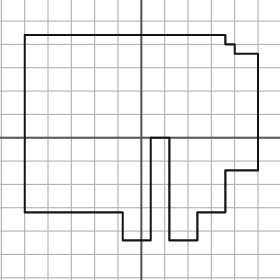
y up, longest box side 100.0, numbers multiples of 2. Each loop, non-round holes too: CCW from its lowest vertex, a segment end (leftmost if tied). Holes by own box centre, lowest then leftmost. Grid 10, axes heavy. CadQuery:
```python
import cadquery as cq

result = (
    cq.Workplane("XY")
    .moveTo(-8.0, -44.0)
    .lineTo(4.0, -44.0)
    .lineTo(4.0, 0.0)
    .lineTo(12.0, 0.0)
    .lineTo(12.0, -44.0)
    .lineTo(24.0, -44.0)
    .lineTo(24.0, -32.0)
    .lineTo(36.0, -32.0)
    .lineTo(36.0, -14.0)
    .lineTo(50.0, -14.0)
    .lineTo(50.0, 36.0)
    .lineTo(40.0, 36.0)
    .lineTo(40.0, 40.0)
    .lineTo(36.0, 40.0)
    .lineTo(36.0, 44.0)
    .lineTo(-50.0, 44.0)
    .lineTo(-50.0, -32.0)
    .lineTo(-8.0, -32.0)
    .close()
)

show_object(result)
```